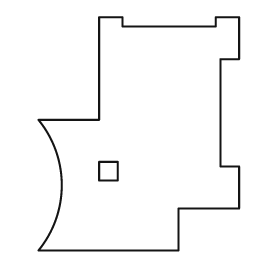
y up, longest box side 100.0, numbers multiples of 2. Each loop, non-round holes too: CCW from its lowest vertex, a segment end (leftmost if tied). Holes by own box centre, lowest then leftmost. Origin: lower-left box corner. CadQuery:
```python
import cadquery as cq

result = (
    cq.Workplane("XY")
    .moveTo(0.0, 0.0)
    .lineTo(60.0, 0.0)
    .lineTo(60.0, 18.0)
    .lineTo(86.0, 18.0)
    .lineTo(86.0, 36.0)
    .lineTo(78.0, 36.0)
    .lineTo(78.0, 82.0)
    .lineTo(86.0, 82.0)
    .lineTo(86.0, 100.0)
    .lineTo(76.0, 100.0)
    .lineTo(76.0, 96.0)
    .lineTo(36.0, 96.0)
    .lineTo(36.0, 100.0)
    .lineTo(26.0, 100.0)
    .lineTo(26.0, 56.0)
    .lineTo(0.0, 56.0)
    .threePointArc((10.0, 28.0), (0.0, 0.0))
    .close()
    .moveTo(26.0, 30.0)
    .lineTo(34.0, 30.0)
    .lineTo(34.0, 38.0)
    .lineTo(26.0, 38.0)
    .close()
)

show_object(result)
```